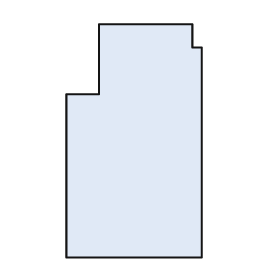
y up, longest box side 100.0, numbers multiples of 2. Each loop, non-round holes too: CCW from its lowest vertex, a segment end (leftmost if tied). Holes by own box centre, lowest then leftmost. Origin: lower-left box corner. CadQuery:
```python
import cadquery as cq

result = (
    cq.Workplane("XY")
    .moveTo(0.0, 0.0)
    .lineTo(58.0, 0.0)
    .lineTo(58.0, 90.0)
    .lineTo(54.0, 90.0)
    .lineTo(54.0, 100.0)
    .lineTo(14.0, 100.0)
    .lineTo(14.0, 70.0)
    .lineTo(0.0, 70.0)
    .close()
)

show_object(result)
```